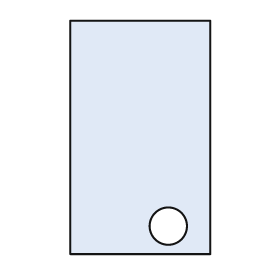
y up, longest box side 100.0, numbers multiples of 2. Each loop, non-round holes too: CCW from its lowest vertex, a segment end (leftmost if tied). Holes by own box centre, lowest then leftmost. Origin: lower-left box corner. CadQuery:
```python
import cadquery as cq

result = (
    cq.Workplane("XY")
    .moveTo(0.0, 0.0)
    .lineTo(60.0, 0.0)
    .lineTo(60.0, 100.0)
    .lineTo(0.0, 100.0)
    .close()
    .moveTo(42.0, 12.0)
    .circle(8.0)
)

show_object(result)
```